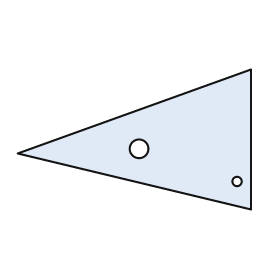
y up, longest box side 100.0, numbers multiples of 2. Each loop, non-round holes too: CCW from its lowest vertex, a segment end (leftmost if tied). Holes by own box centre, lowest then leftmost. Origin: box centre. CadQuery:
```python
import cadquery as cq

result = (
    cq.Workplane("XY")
    .moveTo(50.0, -30.0)
    .lineTo(50.0, 30.0)
    .lineTo(-50.0, -6.0)
    .close()
    .moveTo(44.0, -18.0)
    .circle(2.0)
    .moveTo(2.0, -4.0)
    .circle(4.0)
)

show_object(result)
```